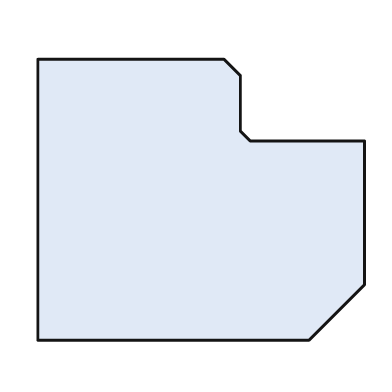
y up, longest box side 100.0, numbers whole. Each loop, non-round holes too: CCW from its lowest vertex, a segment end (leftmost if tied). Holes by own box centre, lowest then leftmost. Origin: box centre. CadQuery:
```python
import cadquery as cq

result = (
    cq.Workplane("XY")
    .moveTo(-50.0, -43.0)
    .lineTo(33.0, -43.0)
    .lineTo(50.0, -26.0)
    .lineTo(50.0, 18.0)
    .lineTo(15.0, 18.0)
    .lineTo(12.0, 21.0)
    .lineTo(12.0, 38.0)
    .lineTo(7.0, 43.0)
    .lineTo(-50.0, 43.0)
    .close()
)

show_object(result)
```